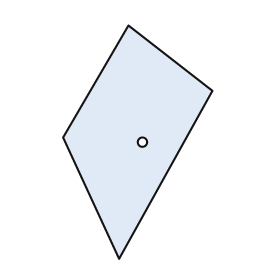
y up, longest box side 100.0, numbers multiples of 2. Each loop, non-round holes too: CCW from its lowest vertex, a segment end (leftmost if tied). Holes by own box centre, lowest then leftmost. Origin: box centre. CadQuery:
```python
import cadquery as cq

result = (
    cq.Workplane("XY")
    .moveTo(-8.0, -50.0)
    .lineTo(32.0, 22.0)
    .lineTo(-4.0, 50.0)
    .lineTo(-32.0, 2.0)
    .close()
    .moveTo(2.0, 0.0)
    .circle(2.0)
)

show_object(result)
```